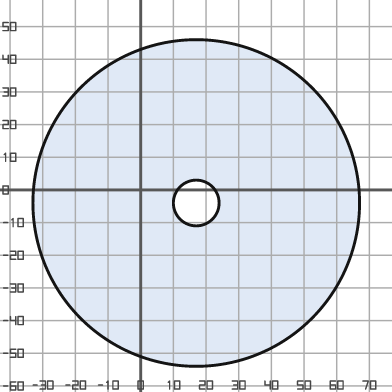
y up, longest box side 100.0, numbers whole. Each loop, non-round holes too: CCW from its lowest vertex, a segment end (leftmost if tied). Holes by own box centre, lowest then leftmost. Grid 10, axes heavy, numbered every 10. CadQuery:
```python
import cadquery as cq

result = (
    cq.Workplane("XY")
    .moveTo(17.0, -4.0)
    .circle(50.0)
    .moveTo(17.0, -4.0)
    .circle(7.0)
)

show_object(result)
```